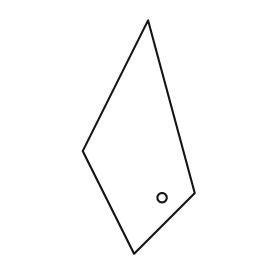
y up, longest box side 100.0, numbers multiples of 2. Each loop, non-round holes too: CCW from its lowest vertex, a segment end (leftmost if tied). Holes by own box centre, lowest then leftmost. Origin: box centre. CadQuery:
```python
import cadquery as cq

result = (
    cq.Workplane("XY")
    .moveTo(-2.0, -50.0)
    .lineTo(24.0, -24.0)
    .lineTo(4.0, 50.0)
    .lineTo(-24.0, -6.0)
    .close()
    .moveTo(10.0, -26.0)
    .circle(2.0)
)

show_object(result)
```